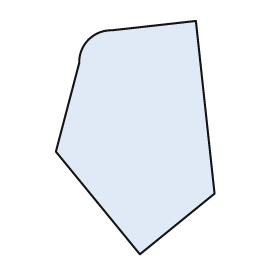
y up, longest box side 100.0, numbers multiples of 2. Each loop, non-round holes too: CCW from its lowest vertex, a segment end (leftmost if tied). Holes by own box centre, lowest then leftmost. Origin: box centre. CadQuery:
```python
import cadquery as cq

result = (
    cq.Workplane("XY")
    .moveTo(2.0, -50.0)
    .lineTo(34.0, -24.0)
    .lineTo(26.0, 50.0)
    .lineTo(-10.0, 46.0)
    .threePointArc((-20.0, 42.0), (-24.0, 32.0))
    .lineTo(-34.0, -6.0)
    .close()
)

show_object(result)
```